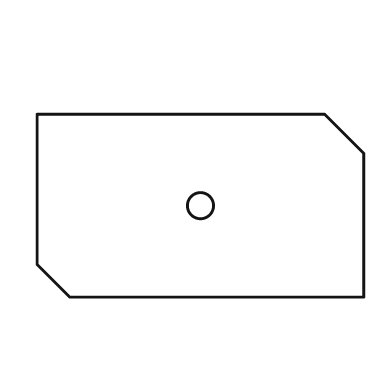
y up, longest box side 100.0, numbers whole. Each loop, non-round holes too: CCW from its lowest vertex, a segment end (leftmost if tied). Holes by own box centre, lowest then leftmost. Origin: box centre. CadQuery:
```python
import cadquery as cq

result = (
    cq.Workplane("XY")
    .moveTo(-40.0, -28.0)
    .lineTo(50.0, -28.0)
    .lineTo(50.0, 16.0)
    .lineTo(38.0, 28.0)
    .lineTo(-50.0, 28.0)
    .lineTo(-50.0, -18.0)
    .close()
    .moveTo(0.0, 0.0)
    .circle(4.0)
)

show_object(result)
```